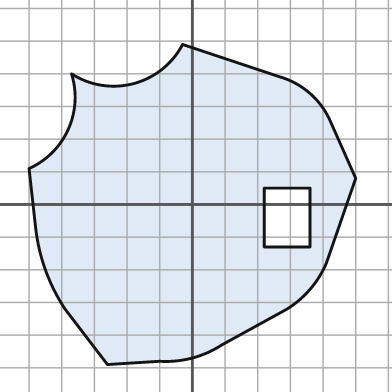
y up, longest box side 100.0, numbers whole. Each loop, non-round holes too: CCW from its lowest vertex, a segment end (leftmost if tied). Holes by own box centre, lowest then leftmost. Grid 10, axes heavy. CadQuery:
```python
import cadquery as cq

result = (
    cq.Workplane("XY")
    .moveTo(-26.0, -49.0)
    .lineTo(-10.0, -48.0)
    .threePointArc((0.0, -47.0), (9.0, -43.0))
    .lineTo(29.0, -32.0)
    .threePointArc((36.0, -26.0), (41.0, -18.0))
    .lineTo(50.0, 8.0)
    .lineTo(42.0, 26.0)
    .threePointArc((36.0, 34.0), (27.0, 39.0))
    .lineTo(-3.0, 49.0)
    .threePointArc((-18.0, 37.0), (-37.0, 40.0))
    .threePointArc((-38.0, 23.0), (-50.0, 11.0))
    .lineTo(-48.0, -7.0)
    .threePointArc((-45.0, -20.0), (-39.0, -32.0))
    .close()
    .moveTo(22.0, -13.0)
    .lineTo(36.0, -13.0)
    .lineTo(36.0, 5.0)
    .lineTo(22.0, 5.0)
    .close()
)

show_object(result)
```